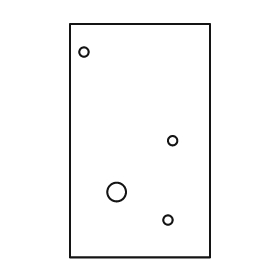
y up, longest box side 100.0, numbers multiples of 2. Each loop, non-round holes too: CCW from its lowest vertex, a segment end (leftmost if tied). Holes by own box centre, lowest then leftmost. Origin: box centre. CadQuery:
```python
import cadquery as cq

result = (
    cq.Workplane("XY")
    .moveTo(-30.0, -50.0)
    .lineTo(30.0, -50.0)
    .lineTo(30.0, 50.0)
    .lineTo(-30.0, 50.0)
    .close()
    .moveTo(12.0, -34.0)
    .circle(2.0)
    .moveTo(-10.0, -22.0)
    .circle(4.0)
    .moveTo(14.0, 0.0)
    .circle(2.0)
    .moveTo(-24.0, 38.0)
    .circle(2.0)
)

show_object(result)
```